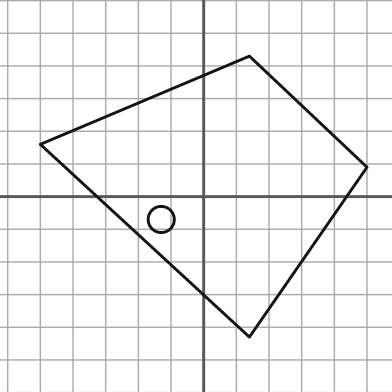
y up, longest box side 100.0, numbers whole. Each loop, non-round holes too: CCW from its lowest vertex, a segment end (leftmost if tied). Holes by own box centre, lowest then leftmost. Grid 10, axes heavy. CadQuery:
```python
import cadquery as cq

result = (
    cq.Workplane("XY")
    .moveTo(14.0, -43.0)
    .lineTo(50.0, 9.0)
    .lineTo(14.0, 43.0)
    .lineTo(-50.0, 16.0)
    .close()
    .moveTo(-13.0, -7.0)
    .circle(4.0)
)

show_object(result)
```